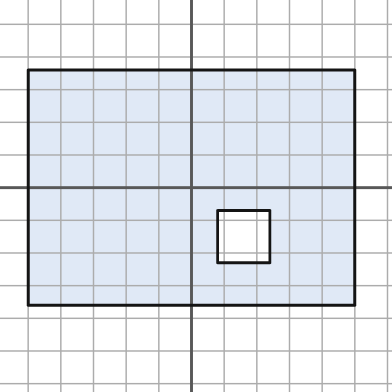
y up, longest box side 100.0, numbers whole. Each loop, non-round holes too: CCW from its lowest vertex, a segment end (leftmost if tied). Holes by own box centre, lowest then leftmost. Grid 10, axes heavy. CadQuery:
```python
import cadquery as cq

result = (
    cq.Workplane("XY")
    .moveTo(-50.0, -36.0)
    .lineTo(50.0, -36.0)
    .lineTo(50.0, 36.0)
    .lineTo(-50.0, 36.0)
    .close()
    .moveTo(8.0, -23.0)
    .lineTo(24.0, -23.0)
    .lineTo(24.0, -7.0)
    .lineTo(8.0, -7.0)
    .close()
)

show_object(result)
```